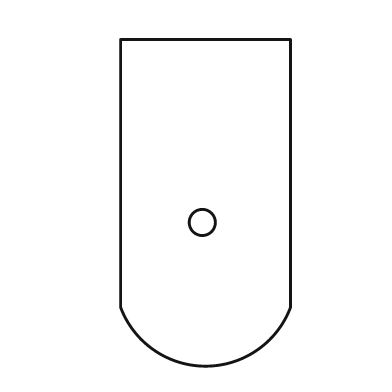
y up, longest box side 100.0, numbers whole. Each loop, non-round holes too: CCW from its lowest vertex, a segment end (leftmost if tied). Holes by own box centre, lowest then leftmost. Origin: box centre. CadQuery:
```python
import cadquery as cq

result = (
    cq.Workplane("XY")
    .moveTo(-26.0, -32.0)
    .threePointArc((0.0, -50.0), (26.0, -32.0))
    .lineTo(26.0, 50.0)
    .lineTo(-26.0, 50.0)
    .close()
    .moveTo(-1.0, -6.0)
    .circle(4.0)
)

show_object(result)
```